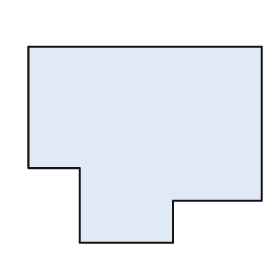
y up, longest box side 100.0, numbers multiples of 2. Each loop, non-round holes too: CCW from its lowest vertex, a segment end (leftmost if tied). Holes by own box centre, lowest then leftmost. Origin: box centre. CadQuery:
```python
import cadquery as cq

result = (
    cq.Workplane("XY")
    .moveTo(-28.0, -42.0)
    .lineTo(12.0, -42.0)
    .lineTo(12.0, -24.0)
    .lineTo(50.0, -24.0)
    .lineTo(50.0, 42.0)
    .lineTo(-50.0, 42.0)
    .lineTo(-50.0, -10.0)
    .lineTo(-28.0, -10.0)
    .close()
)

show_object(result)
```